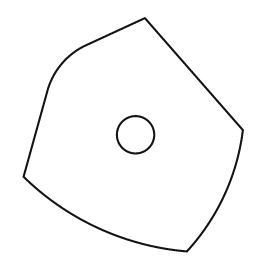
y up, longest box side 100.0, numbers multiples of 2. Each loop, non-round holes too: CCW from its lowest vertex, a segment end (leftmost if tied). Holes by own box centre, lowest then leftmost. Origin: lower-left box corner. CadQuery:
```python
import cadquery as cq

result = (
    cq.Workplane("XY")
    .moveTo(70.0, 0.0)
    .threePointArc((86.0, 24.0), (94.0, 52.0))
    .lineTo(52.0, 100.0)
    .lineTo(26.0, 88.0)
    .threePointArc((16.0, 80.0), (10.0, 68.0))
    .lineTo(0.0, 32.0)
    .threePointArc((32.0, 10.0), (70.0, 0.0))
    .close()
    .moveTo(48.0, 50.0)
    .circle(8.0)
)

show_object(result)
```